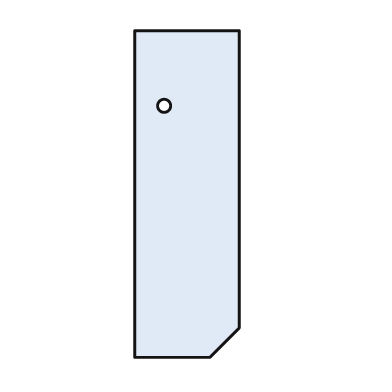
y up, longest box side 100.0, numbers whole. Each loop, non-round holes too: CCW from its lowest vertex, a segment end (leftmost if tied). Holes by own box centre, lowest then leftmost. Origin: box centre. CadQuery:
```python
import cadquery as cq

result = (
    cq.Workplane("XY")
    .moveTo(-16.0, -50.0)
    .lineTo(7.0, -50.0)
    .lineTo(16.0, -41.0)
    .lineTo(16.0, 50.0)
    .lineTo(-16.0, 50.0)
    .close()
    .moveTo(-7.0, 27.0)
    .circle(2.0)
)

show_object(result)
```